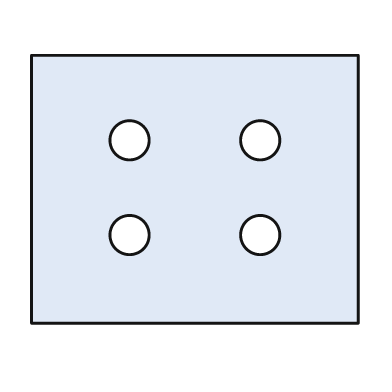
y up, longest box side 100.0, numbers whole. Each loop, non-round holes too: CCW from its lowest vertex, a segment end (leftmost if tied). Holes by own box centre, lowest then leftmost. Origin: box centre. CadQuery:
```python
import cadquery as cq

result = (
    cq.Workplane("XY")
    .moveTo(-50.0, -41.0)
    .lineTo(50.0, -41.0)
    .lineTo(50.0, 41.0)
    .lineTo(-50.0, 41.0)
    .close()
    .moveTo(-20.0, -14.0)
    .circle(6.0)
    .moveTo(20.0, -14.0)
    .circle(6.0)
    .moveTo(-20.0, 15.0)
    .circle(6.0)
    .moveTo(20.0, 15.0)
    .circle(6.0)
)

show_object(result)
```